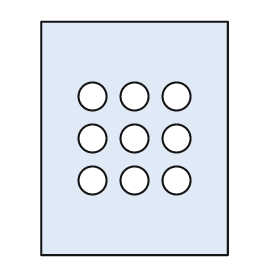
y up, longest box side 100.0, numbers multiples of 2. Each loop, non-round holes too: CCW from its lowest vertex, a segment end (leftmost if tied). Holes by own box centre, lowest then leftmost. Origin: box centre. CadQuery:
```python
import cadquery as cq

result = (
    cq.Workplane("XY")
    .moveTo(-40.0, -50.0)
    .lineTo(40.0, -50.0)
    .lineTo(40.0, 50.0)
    .lineTo(-40.0, 50.0)
    .close()
    .moveTo(-18.0, -18.0)
    .circle(6.0)
    .moveTo(0.0, -18.0)
    .circle(6.0)
    .moveTo(18.0, -18.0)
    .circle(6.0)
    .moveTo(-18.0, 0.0)
    .circle(6.0)
    .moveTo(0.0, 0.0)
    .circle(6.0)
    .moveTo(18.0, 0.0)
    .circle(6.0)
    .moveTo(-18.0, 18.0)
    .circle(6.0)
    .moveTo(0.0, 18.0)
    .circle(6.0)
    .moveTo(18.0, 18.0)
    .circle(6.0)
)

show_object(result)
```